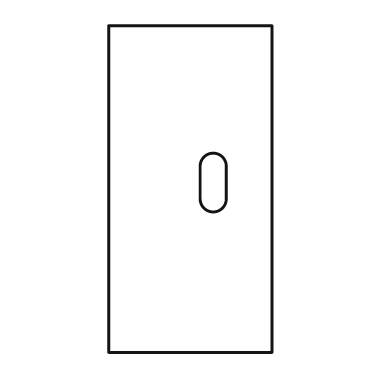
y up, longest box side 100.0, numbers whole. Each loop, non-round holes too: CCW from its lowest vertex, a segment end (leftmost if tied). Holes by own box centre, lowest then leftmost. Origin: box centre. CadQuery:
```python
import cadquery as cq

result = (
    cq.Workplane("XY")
    .moveTo(-25.0, -50.0)
    .lineTo(25.0, -50.0)
    .lineTo(25.0, 50.0)
    .lineTo(-25.0, 50.0)
    .close()
    .moveTo(3.0, -3.0)
    .threePointArc((7.0, -7.0), (11.0, -3.0))
    .lineTo(11.0, 7.0)
    .threePointArc((7.0, 11.0), (3.0, 7.0))
    .close()
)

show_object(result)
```